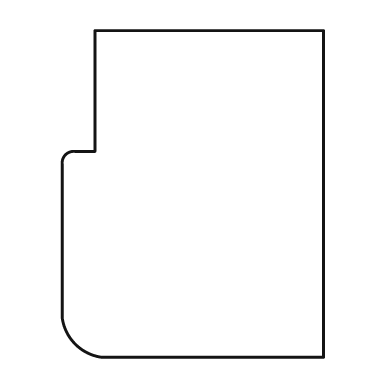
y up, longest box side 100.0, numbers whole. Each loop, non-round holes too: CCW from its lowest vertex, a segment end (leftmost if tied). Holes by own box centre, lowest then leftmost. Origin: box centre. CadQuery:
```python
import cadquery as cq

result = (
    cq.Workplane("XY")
    .moveTo(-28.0, -50.0)
    .lineTo(40.0, -50.0)
    .lineTo(40.0, 50.0)
    .lineTo(-30.0, 50.0)
    .lineTo(-30.0, 13.0)
    .lineTo(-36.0, 13.0)
    .threePointArc((-39.0, 12.0), (-40.0, 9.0))
    .lineTo(-40.0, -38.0)
    .threePointArc((-36.0, -46.0), (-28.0, -50.0))
    .close()
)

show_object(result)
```